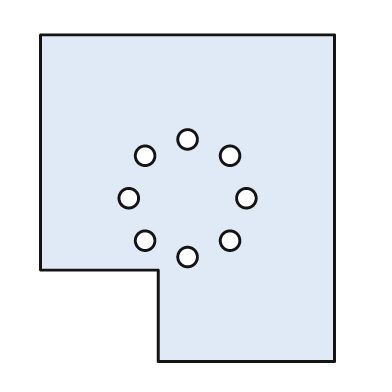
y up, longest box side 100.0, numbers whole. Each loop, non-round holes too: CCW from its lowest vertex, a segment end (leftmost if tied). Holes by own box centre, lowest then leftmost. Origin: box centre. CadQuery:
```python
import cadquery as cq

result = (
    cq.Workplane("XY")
    .moveTo(-9.0, -50.0)
    .lineTo(45.0, -50.0)
    .lineTo(45.0, 50.0)
    .lineTo(-45.0, 50.0)
    .lineTo(-45.0, -22.0)
    .lineTo(-9.0, -22.0)
    .close()
    .moveTo(0.0, -18.0)
    .circle(3.0)
    .moveTo(-13.0, -13.0)
    .circle(3.0)
    .moveTo(13.0, -13.0)
    .circle(3.0)
    .moveTo(-18.0, 0.0)
    .circle(3.0)
    .moveTo(18.0, 0.0)
    .circle(3.0)
    .moveTo(-13.0, 13.0)
    .circle(3.0)
    .moveTo(13.0, 13.0)
    .circle(3.0)
    .moveTo(0.0, 18.0)
    .circle(3.0)
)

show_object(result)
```